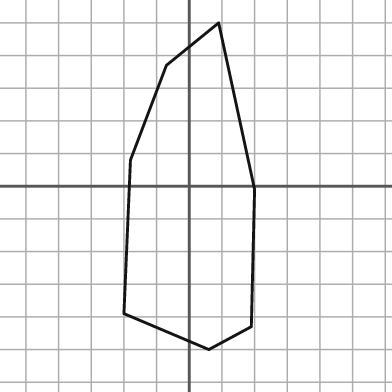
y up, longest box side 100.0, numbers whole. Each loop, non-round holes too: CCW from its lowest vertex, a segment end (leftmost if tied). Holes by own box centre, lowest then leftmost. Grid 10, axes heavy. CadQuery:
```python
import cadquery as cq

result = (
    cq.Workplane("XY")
    .moveTo(6.0, -50.0)
    .lineTo(19.0, -43.0)
    .lineTo(20.0, -1.0)
    .lineTo(9.0, 50.0)
    .lineTo(-7.0, 37.0)
    .lineTo(-18.0, 8.0)
    .lineTo(-20.0, -39.0)
    .close()
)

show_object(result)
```